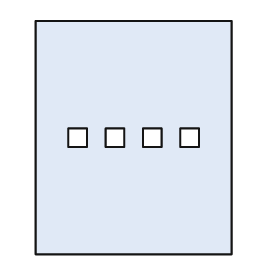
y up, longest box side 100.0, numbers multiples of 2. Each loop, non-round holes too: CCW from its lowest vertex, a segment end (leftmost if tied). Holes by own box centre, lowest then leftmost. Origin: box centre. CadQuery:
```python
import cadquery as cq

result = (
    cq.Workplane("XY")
    .moveTo(-42.0, -50.0)
    .lineTo(42.0, -50.0)
    .lineTo(42.0, 50.0)
    .lineTo(-42.0, 50.0)
    .close()
    .moveTo(-28.0, -4.0)
    .lineTo(-20.0, -4.0)
    .lineTo(-20.0, 4.0)
    .lineTo(-28.0, 4.0)
    .close()
    .moveTo(-12.0, -4.0)
    .lineTo(-4.0, -4.0)
    .lineTo(-4.0, 4.0)
    .lineTo(-12.0, 4.0)
    .close()
    .moveTo(4.0, -4.0)
    .lineTo(12.0, -4.0)
    .lineTo(12.0, 4.0)
    .lineTo(4.0, 4.0)
    .close()
    .moveTo(20.0, -4.0)
    .lineTo(28.0, -4.0)
    .lineTo(28.0, 4.0)
    .lineTo(20.0, 4.0)
    .close()
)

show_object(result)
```